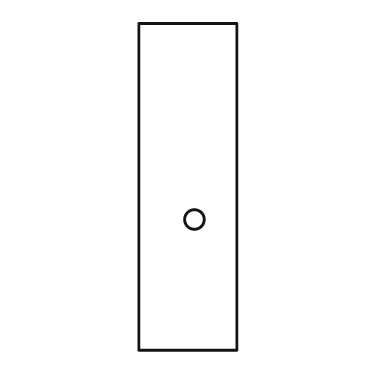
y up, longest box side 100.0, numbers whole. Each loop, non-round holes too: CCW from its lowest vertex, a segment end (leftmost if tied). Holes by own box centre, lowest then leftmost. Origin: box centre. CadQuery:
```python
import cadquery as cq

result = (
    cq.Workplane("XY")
    .moveTo(-15.0, -50.0)
    .lineTo(15.0, -50.0)
    .lineTo(15.0, 50.0)
    .lineTo(-15.0, 50.0)
    .close()
    .moveTo(2.0, -10.0)
    .circle(3.0)
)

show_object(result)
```